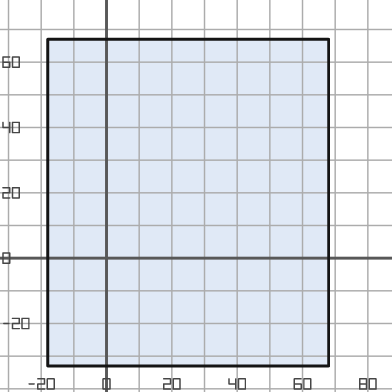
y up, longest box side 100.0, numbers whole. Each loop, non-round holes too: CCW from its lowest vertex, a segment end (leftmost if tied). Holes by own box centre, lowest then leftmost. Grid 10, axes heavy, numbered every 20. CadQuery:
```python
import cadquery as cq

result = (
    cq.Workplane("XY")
    .moveTo(-18.0, -33.0)
    .lineTo(68.0, -33.0)
    .lineTo(68.0, 67.0)
    .lineTo(-18.0, 67.0)
    .close()
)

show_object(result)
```